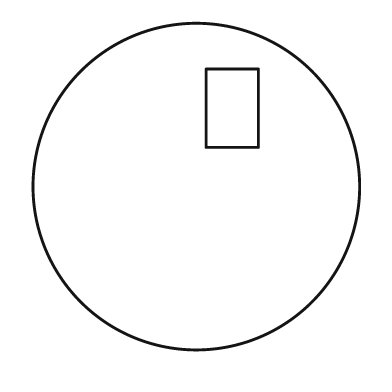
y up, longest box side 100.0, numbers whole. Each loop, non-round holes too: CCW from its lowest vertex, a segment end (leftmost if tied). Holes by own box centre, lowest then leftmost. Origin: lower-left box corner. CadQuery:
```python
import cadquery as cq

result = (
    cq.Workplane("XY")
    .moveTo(50.0, 50.0)
    .circle(50.0)
    .moveTo(53.0, 62.0)
    .lineTo(69.0, 62.0)
    .lineTo(69.0, 86.0)
    .lineTo(53.0, 86.0)
    .close()
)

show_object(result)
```